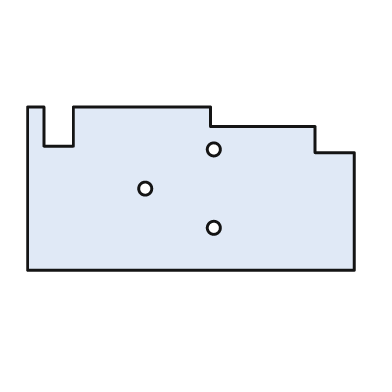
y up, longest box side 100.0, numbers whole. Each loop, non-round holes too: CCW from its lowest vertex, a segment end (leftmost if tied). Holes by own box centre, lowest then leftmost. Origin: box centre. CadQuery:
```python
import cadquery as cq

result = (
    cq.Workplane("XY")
    .moveTo(-50.0, -25.0)
    .lineTo(50.0, -25.0)
    .lineTo(50.0, 11.0)
    .lineTo(38.0, 11.0)
    .lineTo(38.0, 19.0)
    .lineTo(6.0, 19.0)
    .lineTo(6.0, 25.0)
    .lineTo(-36.0, 25.0)
    .lineTo(-36.0, 13.0)
    .lineTo(-45.0, 13.0)
    .lineTo(-45.0, 25.0)
    .lineTo(-50.0, 25.0)
    .close()
    .moveTo(7.0, -12.0)
    .circle(2.0)
    .moveTo(-14.0, 0.0)
    .circle(2.0)
    .moveTo(7.0, 12.0)
    .circle(2.0)
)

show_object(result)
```